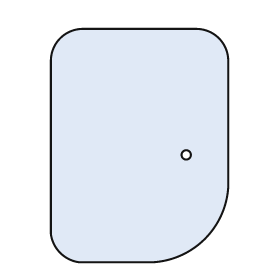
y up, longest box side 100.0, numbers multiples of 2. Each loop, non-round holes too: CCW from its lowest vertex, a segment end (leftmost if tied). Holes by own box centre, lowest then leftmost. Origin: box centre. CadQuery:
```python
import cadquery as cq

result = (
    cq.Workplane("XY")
    .moveTo(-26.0, -50.0)
    .lineTo(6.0, -50.0)
    .threePointArc((28.0, -40.0), (38.0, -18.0))
    .lineTo(38.0, 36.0)
    .threePointArc((34.0, 46.0), (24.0, 50.0))
    .lineTo(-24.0, 50.0)
    .threePointArc((-34.0, 46.0), (-38.0, 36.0))
    .lineTo(-38.0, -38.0)
    .threePointArc((-34.0, -46.0), (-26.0, -50.0))
    .close()
    .moveTo(20.0, -4.0)
    .circle(2.0)
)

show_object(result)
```